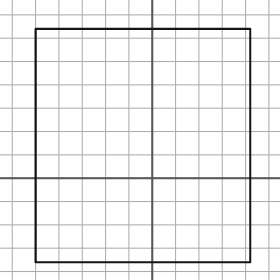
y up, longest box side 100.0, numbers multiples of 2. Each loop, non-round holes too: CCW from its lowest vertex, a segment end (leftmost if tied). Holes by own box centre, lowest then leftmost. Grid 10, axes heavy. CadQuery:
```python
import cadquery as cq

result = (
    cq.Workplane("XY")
    .moveTo(-50.0, -36.0)
    .lineTo(42.0, -36.0)
    .lineTo(42.0, 64.0)
    .lineTo(-50.0, 64.0)
    .close()
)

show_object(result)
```